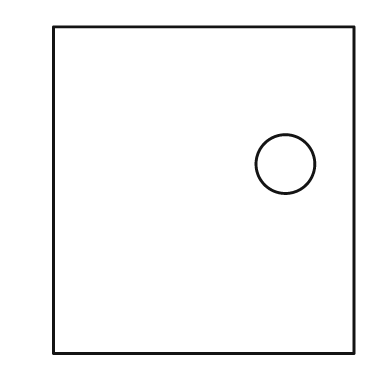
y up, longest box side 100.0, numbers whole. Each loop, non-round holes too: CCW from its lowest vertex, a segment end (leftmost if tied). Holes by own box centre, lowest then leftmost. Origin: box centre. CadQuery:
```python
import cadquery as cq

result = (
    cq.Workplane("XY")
    .moveTo(-46.0, -50.0)
    .lineTo(46.0, -50.0)
    .lineTo(46.0, 50.0)
    .lineTo(-46.0, 50.0)
    .close()
    .moveTo(25.0, 8.0)
    .circle(9.0)
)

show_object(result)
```